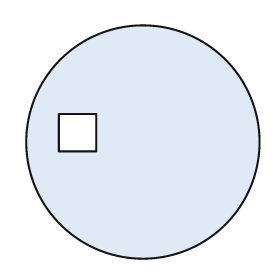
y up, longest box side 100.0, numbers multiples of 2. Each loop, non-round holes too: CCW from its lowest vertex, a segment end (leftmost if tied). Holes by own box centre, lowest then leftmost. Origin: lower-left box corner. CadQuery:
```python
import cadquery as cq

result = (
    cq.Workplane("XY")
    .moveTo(50.0, 50.0)
    .circle(50.0)
    .moveTo(14.0, 46.0)
    .lineTo(30.0, 46.0)
    .lineTo(30.0, 62.0)
    .lineTo(14.0, 62.0)
    .close()
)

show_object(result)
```